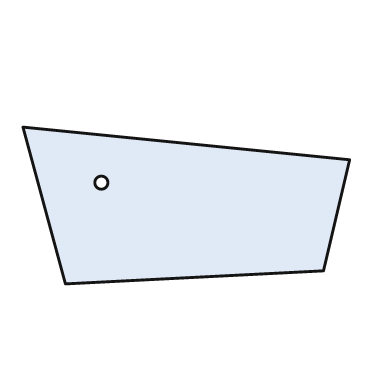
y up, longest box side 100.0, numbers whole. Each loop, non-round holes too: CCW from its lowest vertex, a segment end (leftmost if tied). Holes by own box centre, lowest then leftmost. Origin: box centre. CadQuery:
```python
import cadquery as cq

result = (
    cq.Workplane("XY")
    .moveTo(-37.0, -24.0)
    .lineTo(42.0, -20.0)
    .lineTo(50.0, 14.0)
    .lineTo(-50.0, 24.0)
    .close()
    .moveTo(-26.0, 7.0)
    .circle(2.0)
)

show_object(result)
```